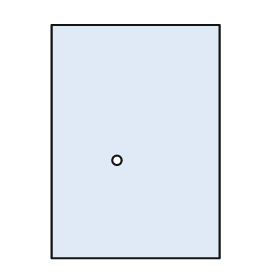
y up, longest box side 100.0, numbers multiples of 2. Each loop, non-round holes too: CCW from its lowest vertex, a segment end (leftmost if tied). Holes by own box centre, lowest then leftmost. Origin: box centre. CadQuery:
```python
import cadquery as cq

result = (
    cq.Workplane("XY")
    .moveTo(-36.0, -50.0)
    .lineTo(36.0, -50.0)
    .lineTo(36.0, 50.0)
    .lineTo(-36.0, 50.0)
    .close()
    .moveTo(-8.0, -8.0)
    .circle(2.0)
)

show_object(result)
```